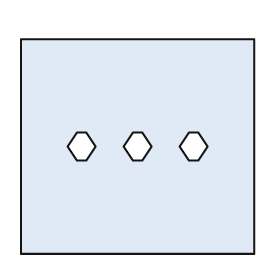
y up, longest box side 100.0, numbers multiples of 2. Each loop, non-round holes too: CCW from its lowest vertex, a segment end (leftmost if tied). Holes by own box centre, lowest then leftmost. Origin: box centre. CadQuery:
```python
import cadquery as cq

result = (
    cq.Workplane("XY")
    .moveTo(-50.0, -46.0)
    .lineTo(50.0, -46.0)
    .lineTo(50.0, 46.0)
    .lineTo(-50.0, 46.0)
    .close()
    .moveTo(-26.0, -6.0)
    .lineTo(-22.0, -6.0)
    .lineTo(-18.0, 0.0)
    .lineTo(-22.0, 6.0)
    .lineTo(-26.0, 6.0)
    .lineTo(-30.0, 0.0)
    .close()
    .moveTo(-2.0, -6.0)
    .lineTo(2.0, -6.0)
    .lineTo(6.0, 0.0)
    .lineTo(2.0, 6.0)
    .lineTo(-2.0, 6.0)
    .lineTo(-6.0, 0.0)
    .close()
    .moveTo(22.0, -6.0)
    .lineTo(26.0, -6.0)
    .lineTo(30.0, 0.0)
    .lineTo(26.0, 6.0)
    .lineTo(22.0, 6.0)
    .lineTo(18.0, 0.0)
    .close()
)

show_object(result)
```